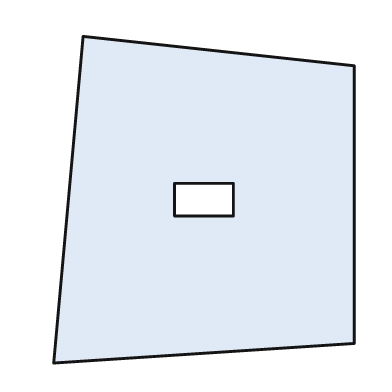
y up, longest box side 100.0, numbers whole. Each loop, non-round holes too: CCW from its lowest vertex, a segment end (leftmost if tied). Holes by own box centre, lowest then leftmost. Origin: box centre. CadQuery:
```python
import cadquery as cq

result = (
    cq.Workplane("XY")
    .moveTo(-46.0, -50.0)
    .lineTo(46.0, -44.0)
    .lineTo(46.0, 41.0)
    .lineTo(-37.0, 50.0)
    .close()
    .moveTo(-9.0, -5.0)
    .lineTo(9.0, -5.0)
    .lineTo(9.0, 5.0)
    .lineTo(-9.0, 5.0)
    .close()
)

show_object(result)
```